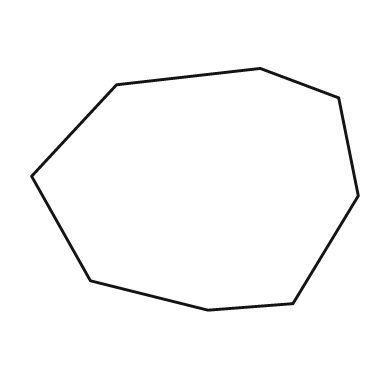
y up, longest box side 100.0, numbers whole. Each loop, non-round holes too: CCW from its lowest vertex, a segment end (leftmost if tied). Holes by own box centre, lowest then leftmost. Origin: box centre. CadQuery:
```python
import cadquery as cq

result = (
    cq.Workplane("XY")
    .moveTo(4.0, -37.0)
    .lineTo(30.0, -35.0)
    .lineTo(50.0, -2.0)
    .lineTo(44.0, 28.0)
    .lineTo(20.0, 37.0)
    .lineTo(-24.0, 32.0)
    .lineTo(-50.0, 4.0)
    .lineTo(-32.0, -28.0)
    .close()
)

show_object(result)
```